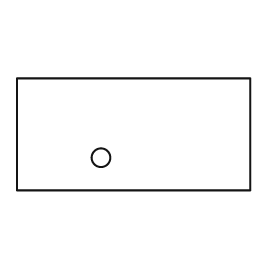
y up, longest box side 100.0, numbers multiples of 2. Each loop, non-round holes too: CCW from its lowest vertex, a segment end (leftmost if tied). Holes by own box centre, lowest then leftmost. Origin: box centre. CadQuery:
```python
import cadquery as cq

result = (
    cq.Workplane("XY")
    .moveTo(-50.0, -24.0)
    .lineTo(50.0, -24.0)
    .lineTo(50.0, 24.0)
    .lineTo(-50.0, 24.0)
    .close()
    .moveTo(-14.0, -10.0)
    .circle(4.0)
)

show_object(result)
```